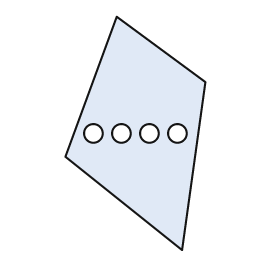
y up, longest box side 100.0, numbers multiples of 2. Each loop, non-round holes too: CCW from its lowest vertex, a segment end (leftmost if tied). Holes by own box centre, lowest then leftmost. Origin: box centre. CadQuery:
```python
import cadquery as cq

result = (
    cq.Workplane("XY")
    .moveTo(20.0, -50.0)
    .lineTo(30.0, 22.0)
    .lineTo(-8.0, 50.0)
    .lineTo(-30.0, -10.0)
    .close()
    .moveTo(-18.0, 0.0)
    .circle(4.0)
    .moveTo(-6.0, 0.0)
    .circle(4.0)
    .moveTo(6.0, 0.0)
    .circle(4.0)
    .moveTo(18.0, 0.0)
    .circle(4.0)
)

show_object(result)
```